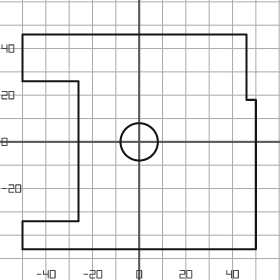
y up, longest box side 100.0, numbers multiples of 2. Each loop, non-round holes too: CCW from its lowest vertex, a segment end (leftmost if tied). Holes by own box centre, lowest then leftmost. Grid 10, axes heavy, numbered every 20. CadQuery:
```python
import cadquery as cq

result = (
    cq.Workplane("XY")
    .moveTo(-50.0, -46.0)
    .lineTo(50.0, -46.0)
    .lineTo(50.0, 18.0)
    .lineTo(46.0, 18.0)
    .lineTo(46.0, 46.0)
    .lineTo(-50.0, 46.0)
    .lineTo(-50.0, 26.0)
    .lineTo(-26.0, 26.0)
    .lineTo(-26.0, -34.0)
    .lineTo(-50.0, -34.0)
    .close()
    .moveTo(0.0, 0.0)
    .circle(8.0)
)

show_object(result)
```